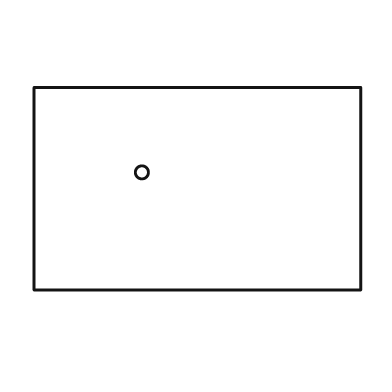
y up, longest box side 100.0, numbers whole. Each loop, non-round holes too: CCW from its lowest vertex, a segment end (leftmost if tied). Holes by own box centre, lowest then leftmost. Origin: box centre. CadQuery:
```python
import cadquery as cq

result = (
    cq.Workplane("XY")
    .moveTo(-50.0, -31.0)
    .lineTo(50.0, -31.0)
    .lineTo(50.0, 31.0)
    .lineTo(-50.0, 31.0)
    .close()
    .moveTo(-17.0, 5.0)
    .circle(2.0)
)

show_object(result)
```